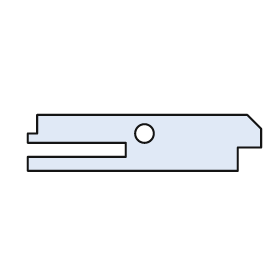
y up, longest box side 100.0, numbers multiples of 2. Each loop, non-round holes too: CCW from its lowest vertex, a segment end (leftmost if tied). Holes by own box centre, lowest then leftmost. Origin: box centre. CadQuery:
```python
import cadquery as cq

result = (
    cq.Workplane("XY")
    .moveTo(-50.0, -12.0)
    .lineTo(40.0, -12.0)
    .lineTo(40.0, -2.0)
    .lineTo(50.0, -2.0)
    .lineTo(50.0, 6.0)
    .lineTo(44.0, 12.0)
    .lineTo(-46.0, 12.0)
    .lineTo(-46.0, 4.0)
    .lineTo(-50.0, 4.0)
    .lineTo(-50.0, 0.0)
    .lineTo(-8.0, 0.0)
    .lineTo(-8.0, -6.0)
    .lineTo(-50.0, -6.0)
    .close()
    .moveTo(0.0, 4.0)
    .circle(4.0)
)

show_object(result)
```